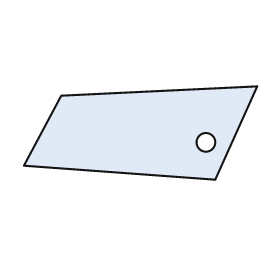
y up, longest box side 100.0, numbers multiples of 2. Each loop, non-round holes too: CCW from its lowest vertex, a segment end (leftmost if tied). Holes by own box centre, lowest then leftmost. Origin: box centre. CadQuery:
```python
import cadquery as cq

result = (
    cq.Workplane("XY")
    .moveTo(32.0, -20.0)
    .lineTo(50.0, 20.0)
    .lineTo(-34.0, 16.0)
    .lineTo(-50.0, -14.0)
    .close()
    .moveTo(28.0, -4.0)
    .circle(4.0)
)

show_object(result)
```